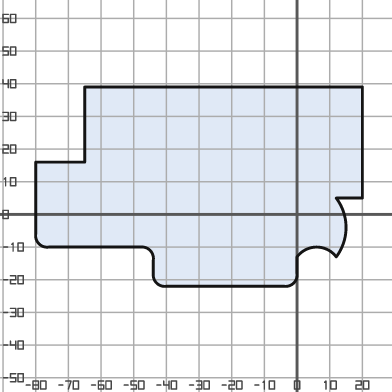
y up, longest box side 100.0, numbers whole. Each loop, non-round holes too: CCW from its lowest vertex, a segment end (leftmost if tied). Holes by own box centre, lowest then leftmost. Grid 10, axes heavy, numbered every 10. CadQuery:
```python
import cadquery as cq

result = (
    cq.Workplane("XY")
    .moveTo(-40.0, -22.0)
    .lineTo(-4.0, -22.0)
    .threePointArc((-1.0, -21.0), (0.0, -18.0))
    .lineTo(0.0, -13.0)
    .threePointArc((6.0, -10.0), (12.0, -13.0))
    .threePointArc((15.0, -4.0), (12.0, 5.0))
    .lineTo(20.0, 5.0)
    .lineTo(20.0, 39.0)
    .lineTo(-65.0, 39.0)
    .lineTo(-65.0, 16.0)
    .lineTo(-80.0, 16.0)
    .lineTo(-80.0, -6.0)
    .threePointArc((-79.0, -9.0), (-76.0, -10.0))
    .lineTo(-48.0, -10.0)
    .threePointArc((-45.0, -11.0), (-44.0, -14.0))
    .lineTo(-44.0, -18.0)
    .threePointArc((-43.0, -21.0), (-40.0, -22.0))
    .close()
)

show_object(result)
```